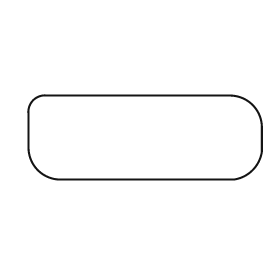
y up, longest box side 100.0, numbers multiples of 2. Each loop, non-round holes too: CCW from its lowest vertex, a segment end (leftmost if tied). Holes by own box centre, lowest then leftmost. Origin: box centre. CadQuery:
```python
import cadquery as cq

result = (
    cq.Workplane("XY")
    .moveTo(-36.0, -18.0)
    .lineTo(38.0, -18.0)
    .threePointArc((46.0, -14.0), (50.0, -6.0))
    .lineTo(50.0, 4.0)
    .threePointArc((46.0, 14.0), (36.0, 18.0))
    .lineTo(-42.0, 18.0)
    .threePointArc((-48.0, 16.0), (-50.0, 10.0))
    .lineTo(-50.0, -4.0)
    .threePointArc((-46.0, -14.0), (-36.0, -18.0))
    .close()
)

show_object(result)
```